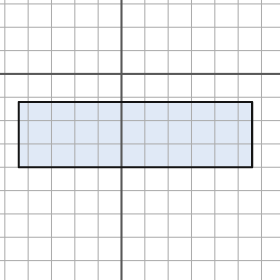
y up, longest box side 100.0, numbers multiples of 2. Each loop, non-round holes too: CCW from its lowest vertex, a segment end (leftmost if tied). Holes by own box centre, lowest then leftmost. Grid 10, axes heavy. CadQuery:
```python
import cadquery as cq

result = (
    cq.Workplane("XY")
    .moveTo(-44.0, -40.0)
    .lineTo(56.0, -40.0)
    .lineTo(56.0, -12.0)
    .lineTo(-44.0, -12.0)
    .close()
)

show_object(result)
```